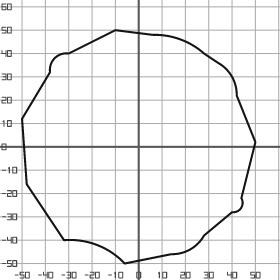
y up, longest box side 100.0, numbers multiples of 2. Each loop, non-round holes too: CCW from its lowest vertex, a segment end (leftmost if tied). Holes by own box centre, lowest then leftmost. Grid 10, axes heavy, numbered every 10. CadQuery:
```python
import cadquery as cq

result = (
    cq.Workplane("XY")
    .moveTo(-6.0, -50.0)
    .lineTo(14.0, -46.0)
    .threePointArc((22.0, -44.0), (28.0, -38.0))
    .lineTo(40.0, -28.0)
    .threePointArc((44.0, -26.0), (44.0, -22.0))
    .lineTo(50.0, 2.0)
    .lineTo(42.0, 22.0)
    .threePointArc((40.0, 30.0), (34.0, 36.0))
    .lineTo(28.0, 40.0)
    .threePointArc((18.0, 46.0), (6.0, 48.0))
    .lineTo(-10.0, 50.0)
    .lineTo(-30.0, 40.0)
    .threePointArc((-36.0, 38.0), (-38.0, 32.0))
    .lineTo(-50.0, 12.0)
    .lineTo(-48.0, -16.0)
    .lineTo(-32.0, -40.0)
    .threePointArc((-18.0, -42.0), (-6.0, -50.0))
    .close()
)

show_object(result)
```